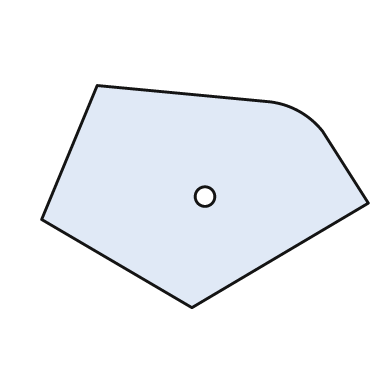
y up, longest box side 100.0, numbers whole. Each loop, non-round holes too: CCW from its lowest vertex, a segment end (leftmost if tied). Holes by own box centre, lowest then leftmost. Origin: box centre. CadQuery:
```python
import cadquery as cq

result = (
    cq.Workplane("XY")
    .moveTo(-4.0, -34.0)
    .lineTo(50.0, -2.0)
    .lineTo(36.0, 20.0)
    .threePointArc((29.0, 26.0), (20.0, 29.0))
    .lineTo(-33.0, 34.0)
    .lineTo(-50.0, -7.0)
    .close()
    .moveTo(0.0, 0.0)
    .circle(3.0)
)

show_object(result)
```